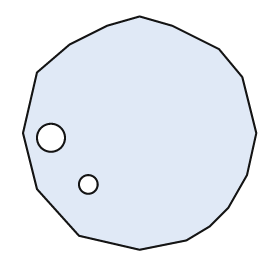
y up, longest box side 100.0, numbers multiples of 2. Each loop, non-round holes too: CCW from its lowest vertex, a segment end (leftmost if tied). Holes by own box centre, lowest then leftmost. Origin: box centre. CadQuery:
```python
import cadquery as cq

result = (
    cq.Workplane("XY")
    .moveTo(0.0, -50.0)
    .lineTo(20.0, -46.0)
    .lineTo(30.0, -40.0)
    .lineTo(38.0, -32.0)
    .lineTo(46.0, -18.0)
    .lineTo(50.0, 0.0)
    .lineTo(44.0, 24.0)
    .lineTo(34.0, 36.0)
    .lineTo(14.0, 46.0)
    .lineTo(0.0, 50.0)
    .lineTo(-14.0, 46.0)
    .lineTo(-30.0, 38.0)
    .lineTo(-44.0, 26.0)
    .lineTo(-50.0, 0.0)
    .lineTo(-44.0, -24.0)
    .lineTo(-26.0, -44.0)
    .close()
    .moveTo(-22.0, -22.0)
    .circle(4.0)
    .moveTo(-38.0, -2.0)
    .circle(6.0)
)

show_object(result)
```